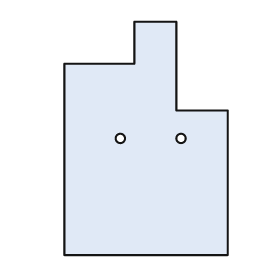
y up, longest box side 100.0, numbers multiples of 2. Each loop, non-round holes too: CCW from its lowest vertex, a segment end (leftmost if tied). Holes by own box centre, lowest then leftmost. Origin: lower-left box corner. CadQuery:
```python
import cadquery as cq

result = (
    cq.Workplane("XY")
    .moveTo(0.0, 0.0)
    .lineTo(70.0, 0.0)
    .lineTo(70.0, 62.0)
    .lineTo(48.0, 62.0)
    .lineTo(48.0, 100.0)
    .lineTo(30.0, 100.0)
    .lineTo(30.0, 82.0)
    .lineTo(0.0, 82.0)
    .close()
    .moveTo(24.0, 50.0)
    .circle(2.0)
    .moveTo(50.0, 50.0)
    .circle(2.0)
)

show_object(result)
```